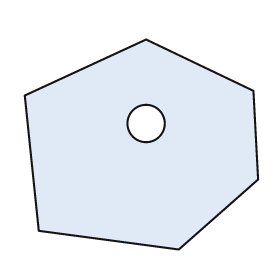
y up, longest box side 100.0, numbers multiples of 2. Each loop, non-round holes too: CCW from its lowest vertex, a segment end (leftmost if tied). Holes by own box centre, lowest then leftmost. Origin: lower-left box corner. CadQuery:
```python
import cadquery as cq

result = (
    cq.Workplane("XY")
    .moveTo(66.0, 0.0)
    .lineTo(100.0, 30.0)
    .lineTo(98.0, 68.0)
    .lineTo(52.0, 90.0)
    .lineTo(0.0, 66.0)
    .lineTo(6.0, 8.0)
    .close()
    .moveTo(52.0, 54.0)
    .circle(8.0)
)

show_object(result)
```